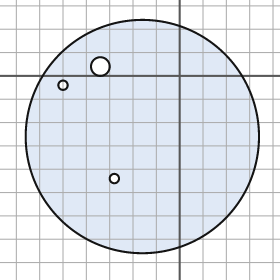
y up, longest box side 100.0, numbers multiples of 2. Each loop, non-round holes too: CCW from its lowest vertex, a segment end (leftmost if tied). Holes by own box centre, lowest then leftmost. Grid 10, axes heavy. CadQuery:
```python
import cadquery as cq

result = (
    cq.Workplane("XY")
    .moveTo(-16.0, -26.0)
    .circle(50.0)
    .moveTo(-28.0, -44.0)
    .circle(2.0)
    .moveTo(-50.0, -4.0)
    .circle(2.0)
    .moveTo(-34.0, 4.0)
    .circle(4.0)
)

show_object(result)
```